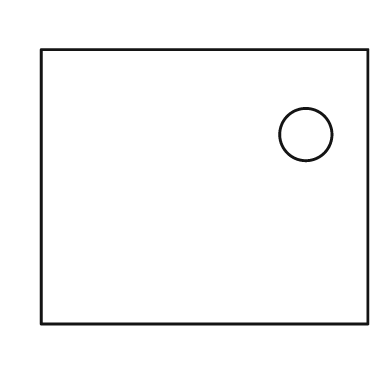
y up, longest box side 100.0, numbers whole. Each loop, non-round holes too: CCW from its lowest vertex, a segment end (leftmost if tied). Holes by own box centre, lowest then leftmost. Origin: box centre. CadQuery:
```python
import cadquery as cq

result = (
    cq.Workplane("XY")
    .moveTo(-50.0, -42.0)
    .lineTo(50.0, -42.0)
    .lineTo(50.0, 42.0)
    .lineTo(-50.0, 42.0)
    .close()
    .moveTo(31.0, 16.0)
    .circle(8.0)
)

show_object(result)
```